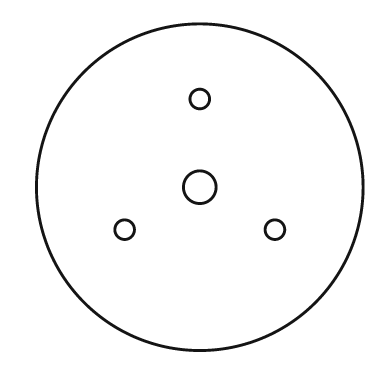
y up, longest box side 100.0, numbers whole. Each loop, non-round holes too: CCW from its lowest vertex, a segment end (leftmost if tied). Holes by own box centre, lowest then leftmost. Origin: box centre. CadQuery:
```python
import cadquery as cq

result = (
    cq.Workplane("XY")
    .moveTo(0.0, 0.0)
    .circle(50.0)
    .moveTo(-23.0, -13.0)
    .circle(3.0)
    .moveTo(23.0, -13.0)
    .circle(3.0)
    .moveTo(0.0, 0.0)
    .circle(5.0)
    .moveTo(0.0, 27.0)
    .circle(3.0)
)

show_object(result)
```